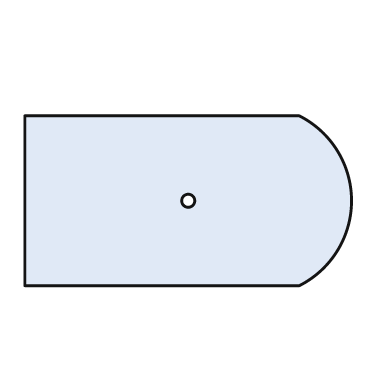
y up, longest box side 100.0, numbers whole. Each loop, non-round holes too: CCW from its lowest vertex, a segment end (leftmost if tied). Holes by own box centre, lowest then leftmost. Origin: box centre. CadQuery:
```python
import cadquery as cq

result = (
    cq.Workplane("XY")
    .moveTo(-50.0, -26.0)
    .lineTo(34.0, -26.0)
    .threePointArc((50.0, 0.0), (34.0, 26.0))
    .lineTo(-50.0, 26.0)
    .close()
    .moveTo(0.0, 0.0)
    .circle(2.0)
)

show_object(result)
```